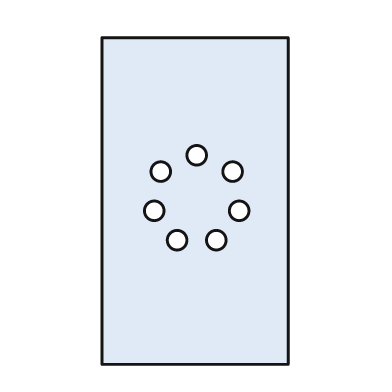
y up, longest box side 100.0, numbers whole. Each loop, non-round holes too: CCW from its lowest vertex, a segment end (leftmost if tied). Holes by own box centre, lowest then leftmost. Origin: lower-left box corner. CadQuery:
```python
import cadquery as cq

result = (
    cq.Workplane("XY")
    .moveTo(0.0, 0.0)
    .lineTo(57.0, 0.0)
    .lineTo(57.0, 100.0)
    .lineTo(0.0, 100.0)
    .close()
    .moveTo(23.0, 38.0)
    .circle(3.0)
    .moveTo(35.0, 38.0)
    .circle(3.0)
    .moveTo(16.0, 47.0)
    .circle(3.0)
    .moveTo(42.0, 47.0)
    .circle(3.0)
    .moveTo(18.0, 59.0)
    .circle(3.0)
    .moveTo(40.0, 59.0)
    .circle(3.0)
    .moveTo(29.0, 64.0)
    .circle(3.0)
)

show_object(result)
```